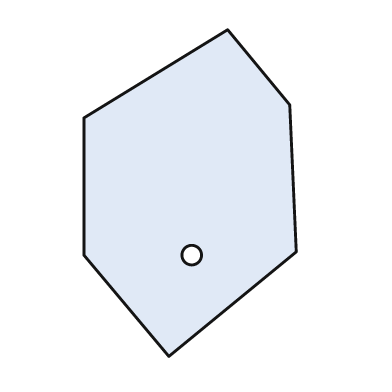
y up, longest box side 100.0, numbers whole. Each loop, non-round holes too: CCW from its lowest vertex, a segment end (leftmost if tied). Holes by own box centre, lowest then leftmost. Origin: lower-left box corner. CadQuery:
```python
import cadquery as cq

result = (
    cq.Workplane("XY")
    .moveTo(26.0, 0.0)
    .lineTo(65.0, 32.0)
    .lineTo(63.0, 77.0)
    .lineTo(44.0, 100.0)
    .lineTo(0.0, 73.0)
    .lineTo(0.0, 31.0)
    .close()
    .moveTo(33.0, 31.0)
    .circle(3.0)
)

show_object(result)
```